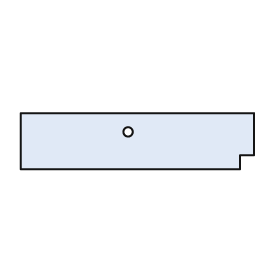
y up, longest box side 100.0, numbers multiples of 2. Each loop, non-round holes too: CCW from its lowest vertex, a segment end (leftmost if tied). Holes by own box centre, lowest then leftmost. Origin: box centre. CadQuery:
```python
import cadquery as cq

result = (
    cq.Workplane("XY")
    .moveTo(-50.0, -12.0)
    .lineTo(44.0, -12.0)
    .lineTo(44.0, -6.0)
    .lineTo(50.0, -6.0)
    .lineTo(50.0, 12.0)
    .lineTo(-50.0, 12.0)
    .close()
    .moveTo(-4.0, 4.0)
    .circle(2.0)
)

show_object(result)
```